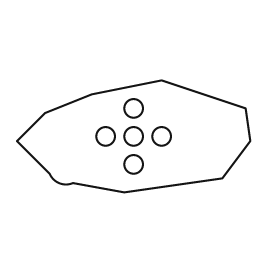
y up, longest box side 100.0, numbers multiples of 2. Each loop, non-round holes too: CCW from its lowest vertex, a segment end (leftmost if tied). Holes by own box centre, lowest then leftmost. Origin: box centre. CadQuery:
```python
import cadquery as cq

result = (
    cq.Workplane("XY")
    .moveTo(-4.0, -24.0)
    .lineTo(38.0, -18.0)
    .lineTo(50.0, -2.0)
    .lineTo(48.0, 12.0)
    .lineTo(12.0, 24.0)
    .lineTo(-18.0, 18.0)
    .lineTo(-38.0, 10.0)
    .lineTo(-50.0, -2.0)
    .lineTo(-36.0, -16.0)
    .threePointArc((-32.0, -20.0), (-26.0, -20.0))
    .close()
    .moveTo(0.0, -12.0)
    .circle(4.0)
    .moveTo(-12.0, 0.0)
    .circle(4.0)
    .moveTo(0.0, 0.0)
    .circle(4.0)
    .moveTo(12.0, 0.0)
    .circle(4.0)
    .moveTo(0.0, 12.0)
    .circle(4.0)
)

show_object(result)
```